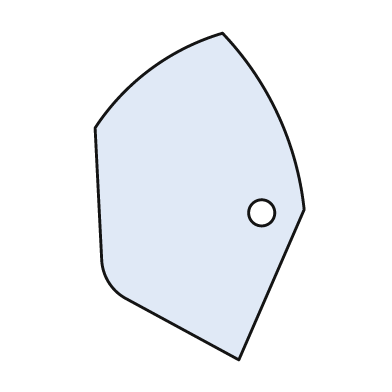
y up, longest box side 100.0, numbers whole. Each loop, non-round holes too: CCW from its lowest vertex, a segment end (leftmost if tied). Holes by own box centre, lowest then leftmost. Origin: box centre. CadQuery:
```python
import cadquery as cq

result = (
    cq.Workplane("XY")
    .moveTo(12.0, -50.0)
    .lineTo(32.0, -4.0)
    .threePointArc((24.0, 25.0), (7.0, 50.0))
    .threePointArc((-15.0, 39.0), (-32.0, 21.0))
    .lineTo(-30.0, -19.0)
    .threePointArc((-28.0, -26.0), (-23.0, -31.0))
    .close()
    .moveTo(19.0, -5.0)
    .circle(4.0)
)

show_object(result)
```